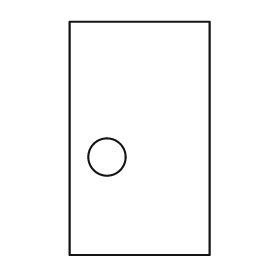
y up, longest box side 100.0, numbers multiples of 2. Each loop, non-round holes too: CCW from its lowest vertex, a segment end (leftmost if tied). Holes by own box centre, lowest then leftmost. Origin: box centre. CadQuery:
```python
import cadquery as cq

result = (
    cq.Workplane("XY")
    .moveTo(-30.0, -50.0)
    .lineTo(30.0, -50.0)
    .lineTo(30.0, 50.0)
    .lineTo(-30.0, 50.0)
    .close()
    .moveTo(-14.0, -8.0)
    .circle(8.0)
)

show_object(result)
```